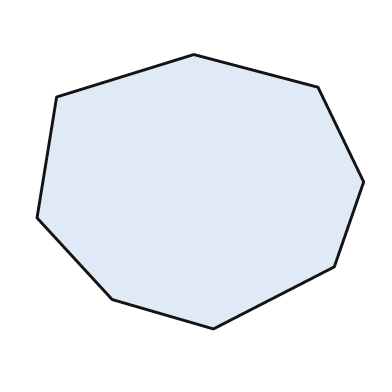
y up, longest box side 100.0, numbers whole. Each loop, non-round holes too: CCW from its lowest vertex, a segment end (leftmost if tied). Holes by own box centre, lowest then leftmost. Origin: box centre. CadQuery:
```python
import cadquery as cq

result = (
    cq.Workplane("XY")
    .moveTo(4.0, -42.0)
    .lineTo(41.0, -23.0)
    .lineTo(50.0, 3.0)
    .lineTo(36.0, 32.0)
    .lineTo(-2.0, 42.0)
    .lineTo(-44.0, 29.0)
    .lineTo(-50.0, -8.0)
    .lineTo(-27.0, -33.0)
    .close()
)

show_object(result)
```